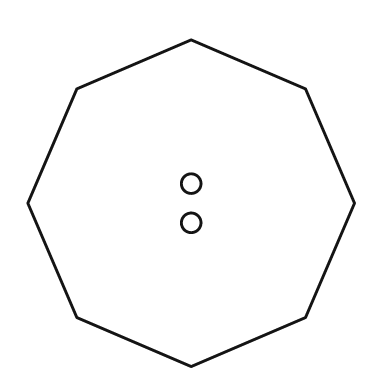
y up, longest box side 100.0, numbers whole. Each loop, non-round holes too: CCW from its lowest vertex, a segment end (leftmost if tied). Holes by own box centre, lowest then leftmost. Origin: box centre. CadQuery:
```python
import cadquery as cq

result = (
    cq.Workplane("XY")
    .moveTo(0.0, -50.0)
    .lineTo(35.0, -35.0)
    .lineTo(50.0, 0.0)
    .lineTo(35.0, 35.0)
    .lineTo(0.0, 50.0)
    .lineTo(-35.0, 35.0)
    .lineTo(-50.0, 0.0)
    .lineTo(-35.0, -35.0)
    .close()
    .moveTo(0.0, -6.0)
    .circle(3.0)
    .moveTo(0.0, 6.0)
    .circle(3.0)
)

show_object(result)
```